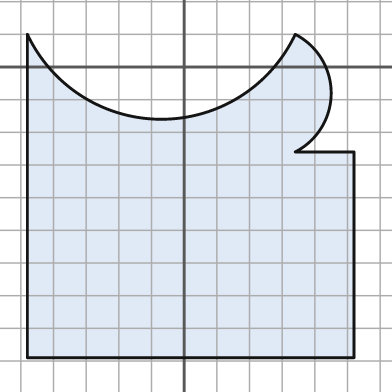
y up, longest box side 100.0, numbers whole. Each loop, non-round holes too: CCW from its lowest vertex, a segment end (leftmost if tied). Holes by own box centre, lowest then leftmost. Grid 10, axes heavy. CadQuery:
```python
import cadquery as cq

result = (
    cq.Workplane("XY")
    .moveTo(-48.0, -89.0)
    .lineTo(52.0, -89.0)
    .lineTo(52.0, -26.0)
    .lineTo(34.0, -26.0)
    .threePointArc((45.0, -8.0), (34.0, 10.0))
    .threePointArc((-7.0, -16.0), (-48.0, 10.0))
    .close()
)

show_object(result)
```